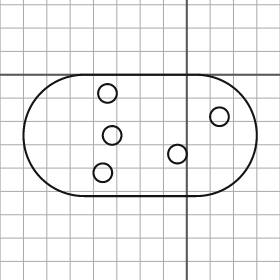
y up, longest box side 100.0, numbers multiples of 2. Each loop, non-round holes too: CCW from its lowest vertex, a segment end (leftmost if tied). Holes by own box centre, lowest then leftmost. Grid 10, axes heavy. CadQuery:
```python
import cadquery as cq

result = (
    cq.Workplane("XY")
    .moveTo(-44.0, -52.0)
    .lineTo(4.0, -52.0)
    .threePointArc((30.0, -26.0), (4.0, 0.0))
    .lineTo(-44.0, 0.0)
    .threePointArc((-70.0, -26.0), (-44.0, -52.0))
    .close()
    .moveTo(-36.0, -42.0)
    .circle(4.0)
    .moveTo(-4.0, -34.0)
    .circle(4.0)
    .moveTo(-32.0, -26.0)
    .circle(4.0)
    .moveTo(14.0, -18.0)
    .circle(4.0)
    .moveTo(-34.0, -8.0)
    .circle(4.0)
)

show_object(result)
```